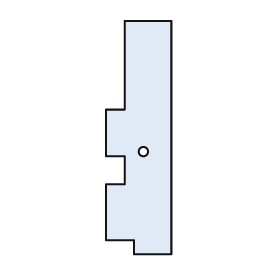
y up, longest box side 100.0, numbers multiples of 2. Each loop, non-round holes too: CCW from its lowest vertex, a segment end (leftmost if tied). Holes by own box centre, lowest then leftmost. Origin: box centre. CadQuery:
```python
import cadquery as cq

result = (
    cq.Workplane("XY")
    .moveTo(-2.0, -50.0)
    .lineTo(14.0, -50.0)
    .lineTo(14.0, 50.0)
    .lineTo(-6.0, 50.0)
    .lineTo(-6.0, 12.0)
    .lineTo(-14.0, 12.0)
    .lineTo(-14.0, -8.0)
    .lineTo(-6.0, -8.0)
    .lineTo(-6.0, -20.0)
    .lineTo(-14.0, -20.0)
    .lineTo(-14.0, -44.0)
    .lineTo(-2.0, -44.0)
    .close()
    .moveTo(2.0, -6.0)
    .circle(2.0)
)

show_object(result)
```